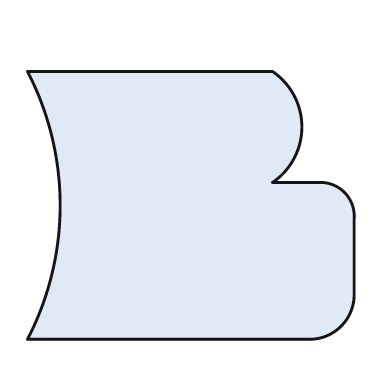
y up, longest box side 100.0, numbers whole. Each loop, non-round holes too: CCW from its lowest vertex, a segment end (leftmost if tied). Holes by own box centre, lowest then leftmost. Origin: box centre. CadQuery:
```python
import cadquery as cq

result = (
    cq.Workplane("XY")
    .moveTo(-50.0, -41.0)
    .lineTo(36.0, -41.0)
    .threePointArc((46.0, -37.0), (50.0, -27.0))
    .lineTo(50.0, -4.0)
    .threePointArc((47.0, 4.0), (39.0, 7.0))
    .lineTo(25.0, 7.0)
    .threePointArc((34.0, 24.0), (25.0, 41.0))
    .lineTo(-50.0, 41.0)
    .threePointArc((-40.0, 0.0), (-50.0, -41.0))
    .close()
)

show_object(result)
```